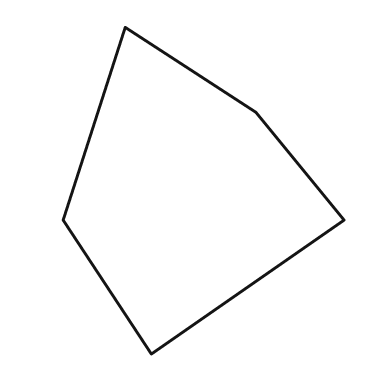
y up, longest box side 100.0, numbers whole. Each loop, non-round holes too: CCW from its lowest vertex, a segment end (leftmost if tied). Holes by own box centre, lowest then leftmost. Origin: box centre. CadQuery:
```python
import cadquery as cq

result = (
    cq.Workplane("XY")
    .moveTo(-16.0, -50.0)
    .lineTo(43.0, -9.0)
    .lineTo(16.0, 24.0)
    .lineTo(-24.0, 50.0)
    .lineTo(-43.0, -9.0)
    .close()
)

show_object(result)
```